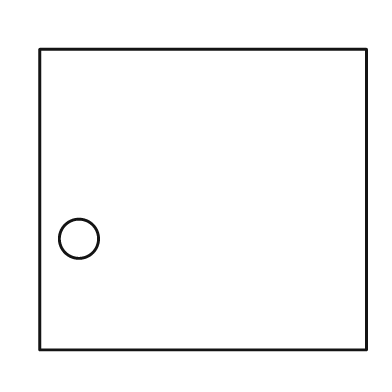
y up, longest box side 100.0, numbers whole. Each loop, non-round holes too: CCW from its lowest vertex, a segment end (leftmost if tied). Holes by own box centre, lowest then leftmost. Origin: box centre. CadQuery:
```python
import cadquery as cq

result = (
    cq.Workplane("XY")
    .moveTo(-50.0, -46.0)
    .lineTo(50.0, -46.0)
    .lineTo(50.0, 46.0)
    .lineTo(-50.0, 46.0)
    .close()
    .moveTo(-38.0, -12.0)
    .circle(6.0)
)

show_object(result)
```